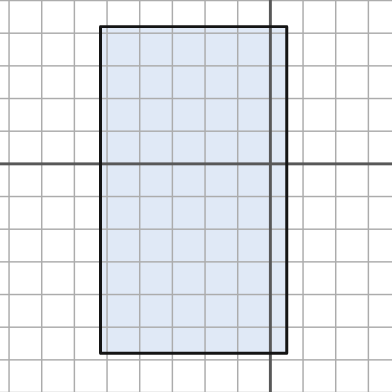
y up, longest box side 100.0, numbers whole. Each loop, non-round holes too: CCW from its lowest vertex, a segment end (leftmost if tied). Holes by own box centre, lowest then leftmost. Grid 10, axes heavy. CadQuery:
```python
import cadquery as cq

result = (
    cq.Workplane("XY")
    .moveTo(-52.0, -58.0)
    .lineTo(5.0, -58.0)
    .lineTo(5.0, 42.0)
    .lineTo(-52.0, 42.0)
    .close()
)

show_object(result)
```